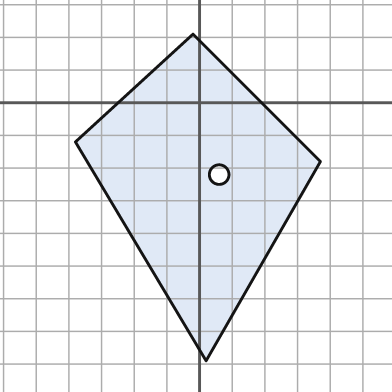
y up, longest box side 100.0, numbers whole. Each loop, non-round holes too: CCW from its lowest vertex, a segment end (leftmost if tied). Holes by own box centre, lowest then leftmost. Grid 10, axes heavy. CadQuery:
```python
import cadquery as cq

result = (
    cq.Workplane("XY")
    .moveTo(2.0, -79.0)
    .lineTo(37.0, -18.0)
    .lineTo(-2.0, 21.0)
    .lineTo(-38.0, -12.0)
    .close()
    .moveTo(6.0, -22.0)
    .circle(3.0)
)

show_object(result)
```